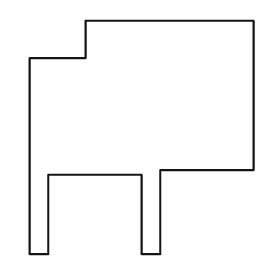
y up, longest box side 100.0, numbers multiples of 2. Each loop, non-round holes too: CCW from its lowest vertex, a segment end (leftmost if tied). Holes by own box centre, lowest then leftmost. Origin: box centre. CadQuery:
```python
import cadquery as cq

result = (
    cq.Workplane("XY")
    .moveTo(-48.0, -50.0)
    .lineTo(-40.0, -50.0)
    .lineTo(-40.0, -16.0)
    .lineTo(0.0, -16.0)
    .lineTo(0.0, -50.0)
    .lineTo(8.0, -50.0)
    .lineTo(8.0, -14.0)
    .lineTo(48.0, -14.0)
    .lineTo(48.0, 50.0)
    .lineTo(-24.0, 50.0)
    .lineTo(-24.0, 34.0)
    .lineTo(-48.0, 34.0)
    .close()
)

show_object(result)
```